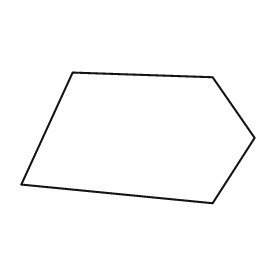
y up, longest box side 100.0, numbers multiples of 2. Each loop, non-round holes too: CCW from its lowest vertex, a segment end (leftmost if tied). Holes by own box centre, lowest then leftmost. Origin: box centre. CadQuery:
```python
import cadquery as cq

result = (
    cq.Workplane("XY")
    .moveTo(32.0, -28.0)
    .lineTo(50.0, 0.0)
    .lineTo(32.0, 26.0)
    .lineTo(-28.0, 28.0)
    .lineTo(-50.0, -20.0)
    .close()
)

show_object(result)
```